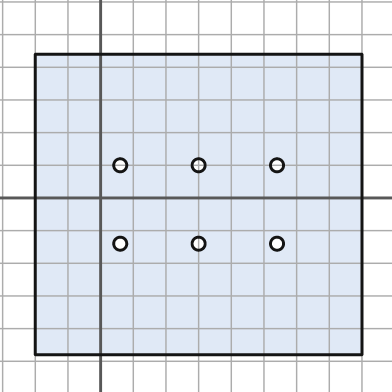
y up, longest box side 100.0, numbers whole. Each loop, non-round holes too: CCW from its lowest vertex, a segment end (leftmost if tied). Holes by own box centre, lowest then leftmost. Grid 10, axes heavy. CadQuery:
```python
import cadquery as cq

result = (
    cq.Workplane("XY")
    .moveTo(-20.0, -48.0)
    .lineTo(80.0, -48.0)
    .lineTo(80.0, 44.0)
    .lineTo(-20.0, 44.0)
    .close()
    .moveTo(6.0, -14.0)
    .circle(2.0)
    .moveTo(30.0, -14.0)
    .circle(2.0)
    .moveTo(54.0, -14.0)
    .circle(2.0)
    .moveTo(6.0, 10.0)
    .circle(2.0)
    .moveTo(30.0, 10.0)
    .circle(2.0)
    .moveTo(54.0, 10.0)
    .circle(2.0)
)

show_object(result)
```